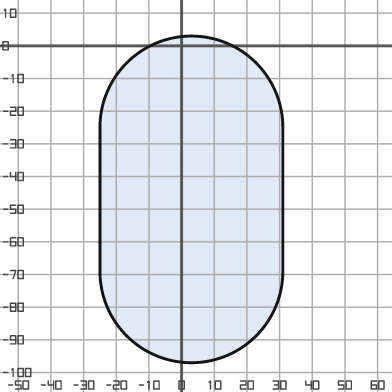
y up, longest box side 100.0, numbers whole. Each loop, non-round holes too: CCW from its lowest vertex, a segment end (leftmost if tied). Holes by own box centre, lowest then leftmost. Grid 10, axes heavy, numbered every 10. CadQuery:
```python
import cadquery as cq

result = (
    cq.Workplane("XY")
    .moveTo(-25.0, -69.0)
    .threePointArc((3.0, -97.0), (31.0, -69.0))
    .lineTo(31.0, -25.0)
    .threePointArc((3.0, 3.0), (-25.0, -25.0))
    .close()
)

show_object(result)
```